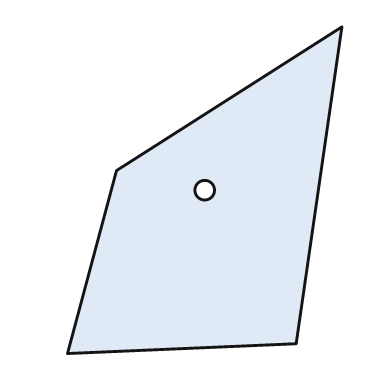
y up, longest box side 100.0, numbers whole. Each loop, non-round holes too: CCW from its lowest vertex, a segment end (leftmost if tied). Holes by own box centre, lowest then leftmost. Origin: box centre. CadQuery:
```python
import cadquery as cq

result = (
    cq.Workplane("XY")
    .moveTo(-42.0, -50.0)
    .lineTo(28.0, -47.0)
    .lineTo(42.0, 50.0)
    .lineTo(-27.0, 6.0)
    .close()
    .moveTo(0.0, 0.0)
    .circle(3.0)
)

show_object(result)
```